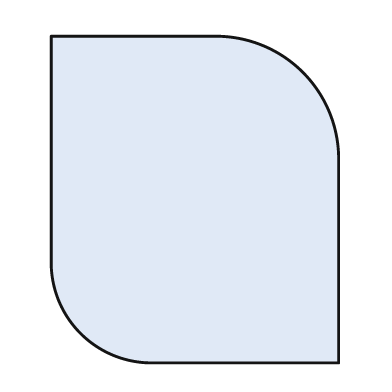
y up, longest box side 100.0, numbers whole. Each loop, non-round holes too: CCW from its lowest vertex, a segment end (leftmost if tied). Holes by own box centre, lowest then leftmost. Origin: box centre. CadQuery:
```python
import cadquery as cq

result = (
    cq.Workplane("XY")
    .moveTo(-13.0, -50.0)
    .lineTo(44.0, -50.0)
    .lineTo(44.0, 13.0)
    .threePointArc((33.0, 39.0), (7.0, 50.0))
    .lineTo(-44.0, 50.0)
    .lineTo(-44.0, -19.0)
    .threePointArc((-35.0, -41.0), (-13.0, -50.0))
    .close()
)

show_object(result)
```